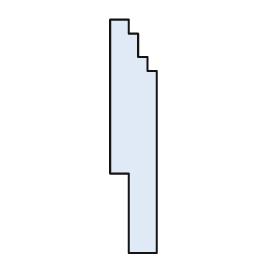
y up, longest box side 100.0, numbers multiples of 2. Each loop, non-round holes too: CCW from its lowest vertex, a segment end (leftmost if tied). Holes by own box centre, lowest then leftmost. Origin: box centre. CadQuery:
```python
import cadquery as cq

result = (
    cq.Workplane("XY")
    .moveTo(-2.0, -50.0)
    .lineTo(10.0, -50.0)
    .lineTo(10.0, 28.0)
    .lineTo(6.0, 28.0)
    .lineTo(6.0, 34.0)
    .lineTo(2.0, 34.0)
    .lineTo(2.0, 44.0)
    .lineTo(-2.0, 44.0)
    .lineTo(-2.0, 50.0)
    .lineTo(-10.0, 50.0)
    .lineTo(-10.0, -16.0)
    .lineTo(-2.0, -16.0)
    .close()
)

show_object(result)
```